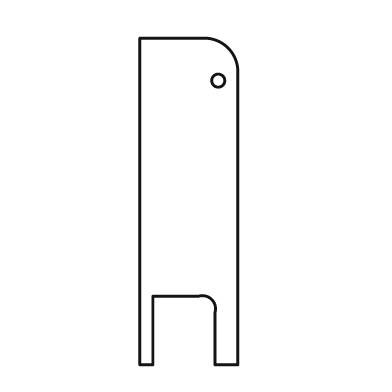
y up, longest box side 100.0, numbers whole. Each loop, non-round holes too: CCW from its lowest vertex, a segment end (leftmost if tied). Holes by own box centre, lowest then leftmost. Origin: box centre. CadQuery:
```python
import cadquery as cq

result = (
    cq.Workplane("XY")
    .moveTo(-15.0, -50.0)
    .lineTo(-11.0, -50.0)
    .lineTo(-11.0, -29.0)
    .lineTo(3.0, -29.0)
    .threePointArc((7.0, -30.0), (8.0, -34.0))
    .lineTo(8.0, -50.0)
    .lineTo(15.0, -50.0)
    .lineTo(15.0, 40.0)
    .threePointArc((12.0, 47.0), (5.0, 50.0))
    .lineTo(-15.0, 50.0)
    .close()
    .moveTo(9.0, 37.0)
    .circle(2.0)
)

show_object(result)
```